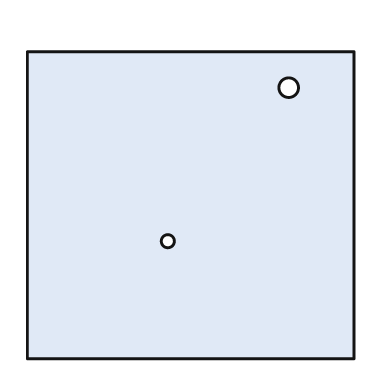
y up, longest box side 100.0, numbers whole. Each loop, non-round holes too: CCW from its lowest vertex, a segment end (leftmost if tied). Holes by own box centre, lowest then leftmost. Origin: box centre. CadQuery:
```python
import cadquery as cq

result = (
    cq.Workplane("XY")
    .moveTo(-50.0, -47.0)
    .lineTo(50.0, -47.0)
    .lineTo(50.0, 47.0)
    .lineTo(-50.0, 47.0)
    .close()
    .moveTo(-7.0, -11.0)
    .circle(2.0)
    .moveTo(30.0, 36.0)
    .circle(3.0)
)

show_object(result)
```